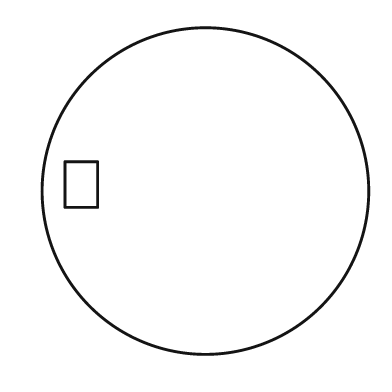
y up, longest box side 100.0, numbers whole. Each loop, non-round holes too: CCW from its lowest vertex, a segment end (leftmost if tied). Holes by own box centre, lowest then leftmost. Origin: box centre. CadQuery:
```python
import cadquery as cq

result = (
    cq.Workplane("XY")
    .moveTo(0.0, 0.0)
    .circle(50.0)
    .moveTo(-43.0, -5.0)
    .lineTo(-33.0, -5.0)
    .lineTo(-33.0, 9.0)
    .lineTo(-43.0, 9.0)
    .close()
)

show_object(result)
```